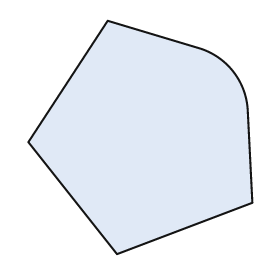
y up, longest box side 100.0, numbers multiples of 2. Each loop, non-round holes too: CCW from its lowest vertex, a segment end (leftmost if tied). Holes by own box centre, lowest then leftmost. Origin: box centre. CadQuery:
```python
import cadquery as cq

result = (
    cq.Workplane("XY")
    .moveTo(-10.0, -50.0)
    .lineTo(48.0, -28.0)
    .lineTo(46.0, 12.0)
    .threePointArc((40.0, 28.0), (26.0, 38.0))
    .lineTo(-14.0, 50.0)
    .lineTo(-48.0, -2.0)
    .close()
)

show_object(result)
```